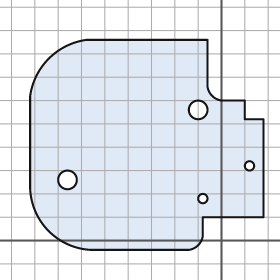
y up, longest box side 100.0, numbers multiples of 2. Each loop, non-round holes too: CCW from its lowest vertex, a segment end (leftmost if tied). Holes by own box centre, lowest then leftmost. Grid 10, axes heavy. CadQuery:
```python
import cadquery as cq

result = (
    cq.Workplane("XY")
    .moveTo(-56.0, -4.0)
    .lineTo(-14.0, -4.0)
    .threePointArc((-10.0, -2.0), (-8.0, 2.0))
    .lineTo(-8.0, 10.0)
    .lineTo(18.0, 10.0)
    .lineTo(18.0, 52.0)
    .lineTo(10.0, 52.0)
    .lineTo(10.0, 60.0)
    .lineTo(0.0, 60.0)
    .threePointArc((-4.0, 62.0), (-6.0, 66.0))
    .lineTo(-6.0, 86.0)
    .lineTo(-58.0, 86.0)
    .threePointArc((-74.0, 78.0), (-82.0, 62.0))
    .lineTo(-82.0, 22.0)
    .threePointArc((-74.0, 4.0), (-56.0, -4.0))
    .close()
    .moveTo(-8.0, 18.0)
    .circle(2.0)
    .moveTo(-66.0, 26.0)
    .circle(4.0)
    .moveTo(12.0, 32.0)
    .circle(2.0)
    .moveTo(-10.0, 56.0)
    .circle(4.0)
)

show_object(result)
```